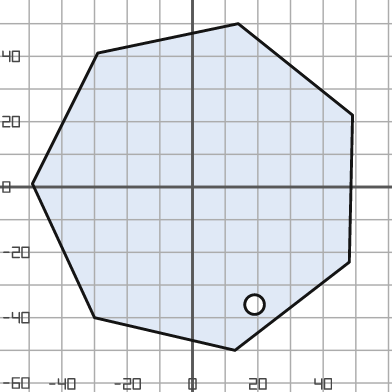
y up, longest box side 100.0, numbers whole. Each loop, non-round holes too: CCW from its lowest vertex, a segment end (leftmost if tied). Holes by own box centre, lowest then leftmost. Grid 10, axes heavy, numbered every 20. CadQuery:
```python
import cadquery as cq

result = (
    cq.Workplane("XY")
    .moveTo(13.0, -50.0)
    .lineTo(48.0, -23.0)
    .lineTo(49.0, 22.0)
    .lineTo(14.0, 50.0)
    .lineTo(-29.0, 41.0)
    .lineTo(-49.0, 1.0)
    .lineTo(-30.0, -40.0)
    .close()
    .moveTo(19.0, -36.0)
    .circle(3.0)
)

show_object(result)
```